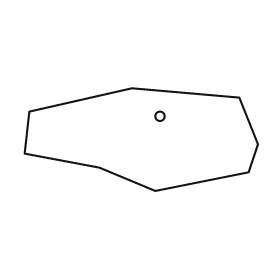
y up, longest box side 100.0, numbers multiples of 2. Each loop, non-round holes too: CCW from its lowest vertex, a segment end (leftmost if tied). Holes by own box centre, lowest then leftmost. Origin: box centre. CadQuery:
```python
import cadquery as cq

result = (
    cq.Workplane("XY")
    .moveTo(6.0, -22.0)
    .lineTo(46.0, -14.0)
    .lineTo(50.0, -2.0)
    .lineTo(42.0, 18.0)
    .lineTo(-4.0, 22.0)
    .lineTo(-48.0, 12.0)
    .lineTo(-50.0, -6.0)
    .lineTo(-18.0, -12.0)
    .close()
    .moveTo(8.0, 10.0)
    .circle(2.0)
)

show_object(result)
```